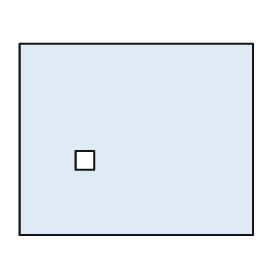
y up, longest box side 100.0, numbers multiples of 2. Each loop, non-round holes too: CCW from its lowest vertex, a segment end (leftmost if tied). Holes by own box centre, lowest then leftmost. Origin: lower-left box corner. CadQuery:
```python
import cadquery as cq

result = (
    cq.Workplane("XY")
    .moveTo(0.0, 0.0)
    .lineTo(100.0, 0.0)
    .lineTo(100.0, 82.0)
    .lineTo(0.0, 82.0)
    .close()
    .moveTo(24.0, 28.0)
    .lineTo(32.0, 28.0)
    .lineTo(32.0, 36.0)
    .lineTo(24.0, 36.0)
    .close()
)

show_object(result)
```